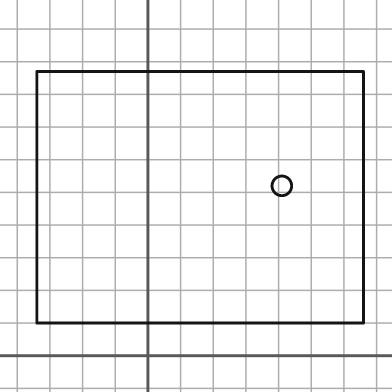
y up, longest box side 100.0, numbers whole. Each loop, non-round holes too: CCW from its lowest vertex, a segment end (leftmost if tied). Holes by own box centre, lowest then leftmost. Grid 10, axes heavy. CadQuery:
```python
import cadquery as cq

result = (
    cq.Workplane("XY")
    .moveTo(-34.0, 10.0)
    .lineTo(66.0, 10.0)
    .lineTo(66.0, 87.0)
    .lineTo(-34.0, 87.0)
    .close()
    .moveTo(41.0, 52.0)
    .circle(3.0)
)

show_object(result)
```